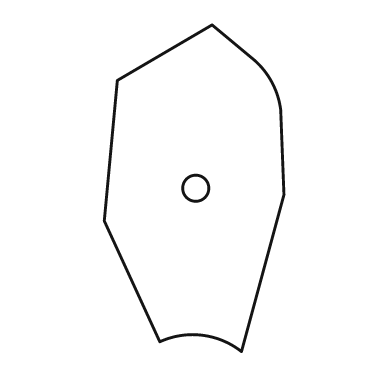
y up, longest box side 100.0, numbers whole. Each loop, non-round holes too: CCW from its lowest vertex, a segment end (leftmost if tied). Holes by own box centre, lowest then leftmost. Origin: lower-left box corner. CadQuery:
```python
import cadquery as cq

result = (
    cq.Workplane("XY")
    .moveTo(42.0, 0.0)
    .lineTo(55.0, 48.0)
    .lineTo(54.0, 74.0)
    .threePointArc((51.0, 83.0), (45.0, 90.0))
    .lineTo(33.0, 100.0)
    .lineTo(4.0, 83.0)
    .lineTo(0.0, 40.0)
    .lineTo(17.0, 3.0)
    .threePointArc((30.0, 5.0), (42.0, 0.0))
    .close()
    .moveTo(28.0, 50.0)
    .circle(4.0)
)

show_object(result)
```